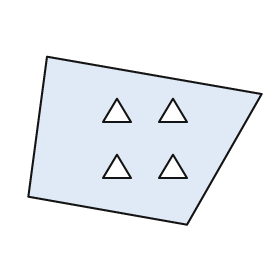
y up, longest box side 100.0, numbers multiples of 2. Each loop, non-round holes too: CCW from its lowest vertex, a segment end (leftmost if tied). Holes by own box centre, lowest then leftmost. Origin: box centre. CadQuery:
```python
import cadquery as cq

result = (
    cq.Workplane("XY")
    .moveTo(18.0, -36.0)
    .lineTo(50.0, 20.0)
    .lineTo(-42.0, 36.0)
    .lineTo(-50.0, -24.0)
    .close()
    .moveTo(-18.0, -16.0)
    .lineTo(-6.0, -16.0)
    .lineTo(-12.0, -6.0)
    .close()
    .moveTo(6.0, -16.0)
    .lineTo(18.0, -16.0)
    .lineTo(12.0, -6.0)
    .close()
    .moveTo(-18.0, 8.0)
    .lineTo(-6.0, 8.0)
    .lineTo(-12.0, 18.0)
    .close()
    .moveTo(6.0, 8.0)
    .lineTo(18.0, 8.0)
    .lineTo(12.0, 18.0)
    .close()
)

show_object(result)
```